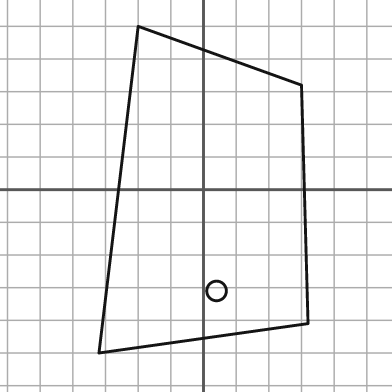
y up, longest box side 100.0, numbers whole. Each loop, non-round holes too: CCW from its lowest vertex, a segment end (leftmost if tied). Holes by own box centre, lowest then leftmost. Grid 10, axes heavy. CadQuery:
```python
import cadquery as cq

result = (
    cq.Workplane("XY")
    .moveTo(-32.0, -50.0)
    .lineTo(32.0, -41.0)
    .lineTo(30.0, 32.0)
    .lineTo(-20.0, 50.0)
    .close()
    .moveTo(4.0, -31.0)
    .circle(3.0)
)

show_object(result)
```